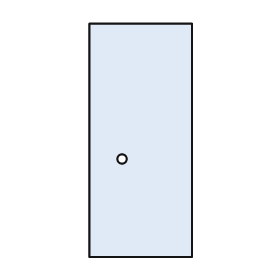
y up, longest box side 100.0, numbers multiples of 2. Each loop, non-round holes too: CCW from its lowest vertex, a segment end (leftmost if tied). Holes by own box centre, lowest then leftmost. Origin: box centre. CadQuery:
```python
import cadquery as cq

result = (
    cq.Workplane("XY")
    .moveTo(-22.0, -50.0)
    .lineTo(22.0, -50.0)
    .lineTo(22.0, 50.0)
    .lineTo(-22.0, 50.0)
    .close()
    .moveTo(-8.0, -8.0)
    .circle(2.0)
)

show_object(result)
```